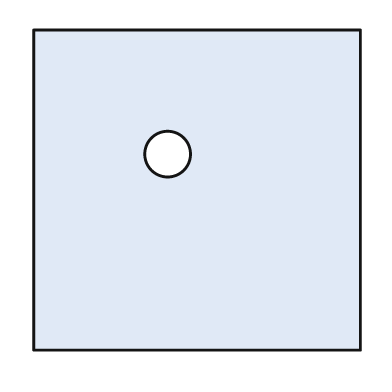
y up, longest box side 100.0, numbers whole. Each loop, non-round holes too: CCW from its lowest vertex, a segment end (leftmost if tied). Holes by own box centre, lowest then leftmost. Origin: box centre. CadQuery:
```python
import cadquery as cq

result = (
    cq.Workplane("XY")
    .moveTo(-50.0, -49.0)
    .lineTo(50.0, -49.0)
    .lineTo(50.0, 49.0)
    .lineTo(-50.0, 49.0)
    .close()
    .moveTo(-9.0, 11.0)
    .circle(7.0)
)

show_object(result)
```